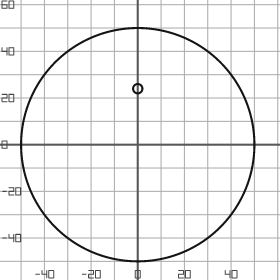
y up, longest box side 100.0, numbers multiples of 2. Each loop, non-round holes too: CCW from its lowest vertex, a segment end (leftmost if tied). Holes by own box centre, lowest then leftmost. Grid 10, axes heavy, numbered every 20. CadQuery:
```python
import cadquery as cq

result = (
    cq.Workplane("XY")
    .moveTo(0.0, 0.0)
    .circle(50.0)
    .moveTo(0.0, 24.0)
    .circle(2.0)
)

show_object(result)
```